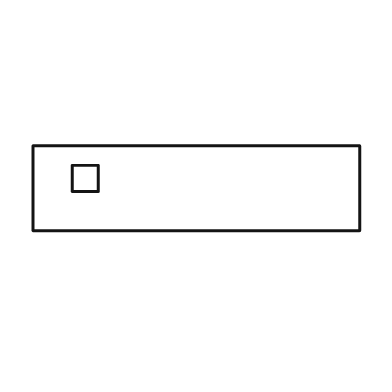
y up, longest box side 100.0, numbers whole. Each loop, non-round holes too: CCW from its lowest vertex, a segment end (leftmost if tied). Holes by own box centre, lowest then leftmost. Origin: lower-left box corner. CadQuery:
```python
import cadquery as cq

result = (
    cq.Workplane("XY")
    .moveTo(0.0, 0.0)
    .lineTo(100.0, 0.0)
    .lineTo(100.0, 26.0)
    .lineTo(0.0, 26.0)
    .close()
    .moveTo(12.0, 12.0)
    .lineTo(20.0, 12.0)
    .lineTo(20.0, 20.0)
    .lineTo(12.0, 20.0)
    .close()
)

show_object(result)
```